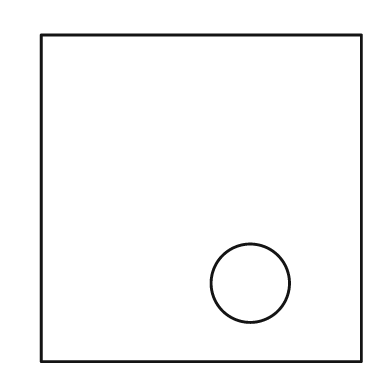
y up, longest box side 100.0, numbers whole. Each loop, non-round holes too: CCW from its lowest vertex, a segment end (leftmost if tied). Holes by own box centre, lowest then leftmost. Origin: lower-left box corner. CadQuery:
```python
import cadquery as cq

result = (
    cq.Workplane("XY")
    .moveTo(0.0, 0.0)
    .lineTo(98.0, 0.0)
    .lineTo(98.0, 100.0)
    .lineTo(0.0, 100.0)
    .close()
    .moveTo(64.0, 24.0)
    .circle(12.0)
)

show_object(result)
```